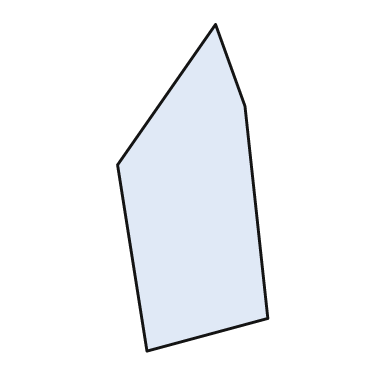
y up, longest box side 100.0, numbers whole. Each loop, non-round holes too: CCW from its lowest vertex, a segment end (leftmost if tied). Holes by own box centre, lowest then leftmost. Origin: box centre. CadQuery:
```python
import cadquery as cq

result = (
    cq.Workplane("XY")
    .moveTo(-14.0, -50.0)
    .lineTo(23.0, -40.0)
    .lineTo(16.0, 25.0)
    .lineTo(7.0, 50.0)
    .lineTo(-23.0, 7.0)
    .close()
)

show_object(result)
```